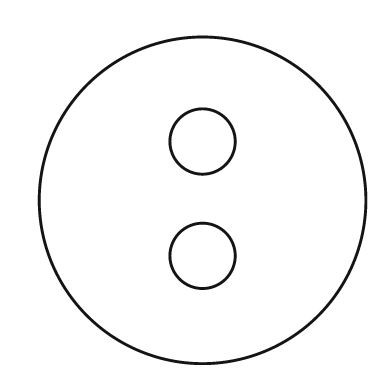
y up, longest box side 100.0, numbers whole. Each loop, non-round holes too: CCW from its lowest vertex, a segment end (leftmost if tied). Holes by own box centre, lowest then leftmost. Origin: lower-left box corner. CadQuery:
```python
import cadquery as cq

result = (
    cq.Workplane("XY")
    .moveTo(50.0, 50.0)
    .circle(50.0)
    .moveTo(50.0, 33.0)
    .circle(10.0)
    .moveTo(50.0, 68.0)
    .circle(10.0)
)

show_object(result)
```